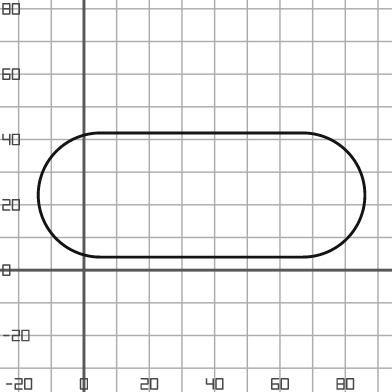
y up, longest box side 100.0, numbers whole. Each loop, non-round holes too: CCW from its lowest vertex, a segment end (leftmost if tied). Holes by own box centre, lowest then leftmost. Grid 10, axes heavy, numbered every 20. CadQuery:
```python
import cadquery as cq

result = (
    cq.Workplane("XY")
    .moveTo(5.0, 4.0)
    .lineTo(67.0, 4.0)
    .threePointArc((86.0, 23.0), (67.0, 42.0))
    .lineTo(5.0, 42.0)
    .threePointArc((-14.0, 23.0), (5.0, 4.0))
    .close()
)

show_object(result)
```